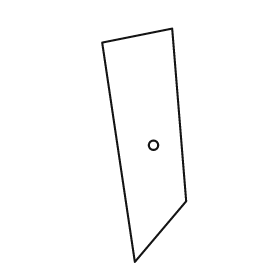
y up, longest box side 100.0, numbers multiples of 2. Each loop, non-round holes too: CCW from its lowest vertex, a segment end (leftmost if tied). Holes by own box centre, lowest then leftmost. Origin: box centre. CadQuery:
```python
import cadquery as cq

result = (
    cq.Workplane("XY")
    .moveTo(-4.0, -50.0)
    .lineTo(18.0, -24.0)
    .lineTo(12.0, 50.0)
    .lineTo(-18.0, 44.0)
    .close()
    .moveTo(4.0, 0.0)
    .circle(2.0)
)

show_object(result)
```